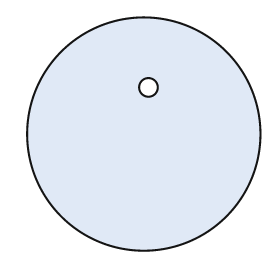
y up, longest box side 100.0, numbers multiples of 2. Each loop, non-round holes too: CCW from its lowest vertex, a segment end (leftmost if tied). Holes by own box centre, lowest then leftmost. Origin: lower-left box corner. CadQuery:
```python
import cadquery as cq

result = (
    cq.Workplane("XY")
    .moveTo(50.0, 50.0)
    .circle(50.0)
    .moveTo(52.0, 70.0)
    .circle(4.0)
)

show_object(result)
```